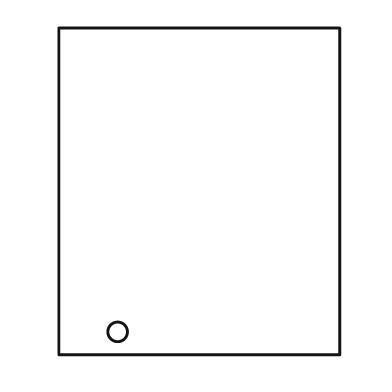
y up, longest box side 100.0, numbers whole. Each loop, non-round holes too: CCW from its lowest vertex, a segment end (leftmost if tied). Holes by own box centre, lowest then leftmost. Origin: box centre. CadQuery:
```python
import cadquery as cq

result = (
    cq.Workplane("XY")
    .moveTo(-43.0, -50.0)
    .lineTo(43.0, -50.0)
    .lineTo(43.0, 50.0)
    .lineTo(-43.0, 50.0)
    .close()
    .moveTo(-25.0, -43.0)
    .circle(3.0)
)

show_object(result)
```